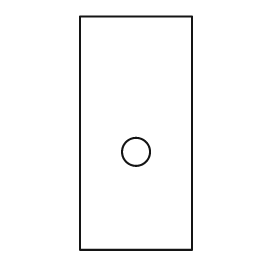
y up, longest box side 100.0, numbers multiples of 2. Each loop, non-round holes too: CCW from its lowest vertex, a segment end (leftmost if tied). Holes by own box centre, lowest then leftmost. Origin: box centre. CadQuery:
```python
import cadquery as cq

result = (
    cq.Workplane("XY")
    .moveTo(-24.0, -50.0)
    .lineTo(24.0, -50.0)
    .lineTo(24.0, 50.0)
    .lineTo(-24.0, 50.0)
    .close()
    .moveTo(0.0, -8.0)
    .circle(6.0)
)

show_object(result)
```